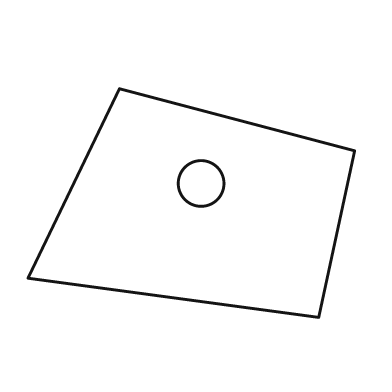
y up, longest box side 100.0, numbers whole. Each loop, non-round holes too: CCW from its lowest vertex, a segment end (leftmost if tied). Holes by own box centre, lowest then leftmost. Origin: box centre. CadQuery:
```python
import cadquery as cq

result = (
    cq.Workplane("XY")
    .moveTo(39.0, -35.0)
    .lineTo(50.0, 16.0)
    .lineTo(-22.0, 35.0)
    .lineTo(-50.0, -23.0)
    .close()
    .moveTo(3.0, 6.0)
    .circle(7.0)
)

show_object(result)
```